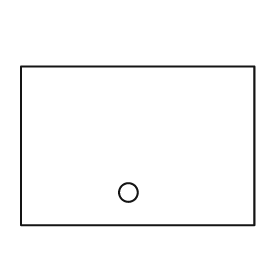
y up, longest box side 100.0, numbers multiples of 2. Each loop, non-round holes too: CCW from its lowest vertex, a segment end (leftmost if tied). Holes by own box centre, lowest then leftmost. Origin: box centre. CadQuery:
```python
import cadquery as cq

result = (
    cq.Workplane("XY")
    .moveTo(-50.0, -34.0)
    .lineTo(50.0, -34.0)
    .lineTo(50.0, 34.0)
    .lineTo(-50.0, 34.0)
    .close()
    .moveTo(-4.0, -20.0)
    .circle(4.0)
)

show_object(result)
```